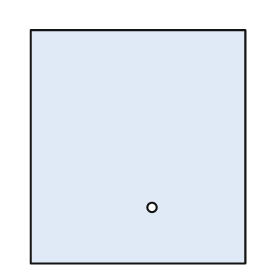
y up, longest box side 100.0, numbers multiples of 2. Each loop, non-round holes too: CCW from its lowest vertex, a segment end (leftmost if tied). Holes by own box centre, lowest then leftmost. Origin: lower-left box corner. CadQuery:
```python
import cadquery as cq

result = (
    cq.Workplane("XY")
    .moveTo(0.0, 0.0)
    .lineTo(92.0, 0.0)
    .lineTo(92.0, 100.0)
    .lineTo(0.0, 100.0)
    .close()
    .moveTo(52.0, 24.0)
    .circle(2.0)
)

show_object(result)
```